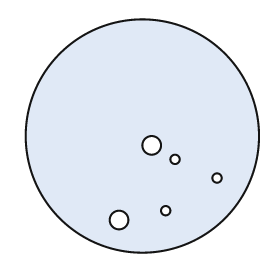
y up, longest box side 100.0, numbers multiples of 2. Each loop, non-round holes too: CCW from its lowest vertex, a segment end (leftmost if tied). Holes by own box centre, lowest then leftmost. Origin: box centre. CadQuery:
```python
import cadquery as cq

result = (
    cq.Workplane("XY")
    .moveTo(0.0, 0.0)
    .circle(50.0)
    .moveTo(-10.0, -36.0)
    .circle(4.0)
    .moveTo(10.0, -32.0)
    .circle(2.0)
    .moveTo(32.0, -18.0)
    .circle(2.0)
    .moveTo(14.0, -10.0)
    .circle(2.0)
    .moveTo(4.0, -4.0)
    .circle(4.0)
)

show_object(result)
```